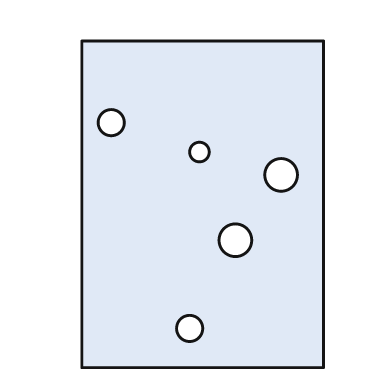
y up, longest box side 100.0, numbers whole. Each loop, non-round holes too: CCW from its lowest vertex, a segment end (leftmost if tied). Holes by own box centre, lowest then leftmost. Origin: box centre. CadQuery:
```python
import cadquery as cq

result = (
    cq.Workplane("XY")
    .moveTo(-37.0, -50.0)
    .lineTo(37.0, -50.0)
    .lineTo(37.0, 50.0)
    .lineTo(-37.0, 50.0)
    .close()
    .moveTo(-4.0, -38.0)
    .circle(4.0)
    .moveTo(10.0, -11.0)
    .circle(5.0)
    .moveTo(24.0, 9.0)
    .circle(5.0)
    .moveTo(-1.0, 16.0)
    .circle(3.0)
    .moveTo(-28.0, 25.0)
    .circle(4.0)
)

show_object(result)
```